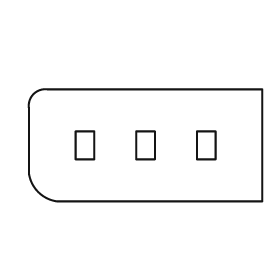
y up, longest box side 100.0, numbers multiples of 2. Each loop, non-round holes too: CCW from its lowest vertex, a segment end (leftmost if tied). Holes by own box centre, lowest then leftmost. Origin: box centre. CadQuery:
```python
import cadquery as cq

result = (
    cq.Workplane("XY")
    .moveTo(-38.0, -24.0)
    .lineTo(50.0, -24.0)
    .lineTo(50.0, 24.0)
    .lineTo(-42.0, 24.0)
    .threePointArc((-48.0, 22.0), (-50.0, 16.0))
    .lineTo(-50.0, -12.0)
    .threePointArc((-46.0, -20.0), (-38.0, -24.0))
    .close()
    .moveTo(-30.0, -6.0)
    .lineTo(-22.0, -6.0)
    .lineTo(-22.0, 6.0)
    .lineTo(-30.0, 6.0)
    .close()
    .moveTo(-4.0, -6.0)
    .lineTo(4.0, -6.0)
    .lineTo(4.0, 6.0)
    .lineTo(-4.0, 6.0)
    .close()
    .moveTo(22.0, -6.0)
    .lineTo(30.0, -6.0)
    .lineTo(30.0, 6.0)
    .lineTo(22.0, 6.0)
    .close()
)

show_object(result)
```